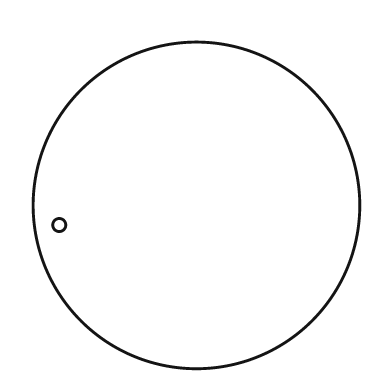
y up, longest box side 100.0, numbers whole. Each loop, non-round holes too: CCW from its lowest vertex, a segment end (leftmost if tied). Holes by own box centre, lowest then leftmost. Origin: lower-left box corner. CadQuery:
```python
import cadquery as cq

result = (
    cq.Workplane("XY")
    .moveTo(50.0, 50.0)
    .circle(50.0)
    .moveTo(8.0, 44.0)
    .circle(2.0)
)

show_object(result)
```